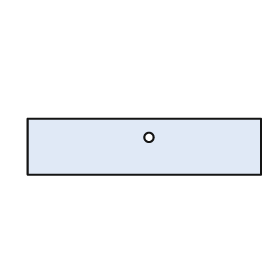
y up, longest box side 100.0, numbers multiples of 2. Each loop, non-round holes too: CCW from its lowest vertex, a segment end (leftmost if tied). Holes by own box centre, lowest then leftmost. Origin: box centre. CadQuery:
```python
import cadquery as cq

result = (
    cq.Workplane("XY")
    .moveTo(-50.0, -12.0)
    .lineTo(50.0, -12.0)
    .lineTo(50.0, 12.0)
    .lineTo(-50.0, 12.0)
    .close()
    .moveTo(2.0, 4.0)
    .circle(2.0)
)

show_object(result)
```